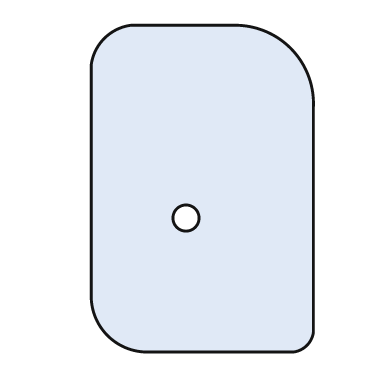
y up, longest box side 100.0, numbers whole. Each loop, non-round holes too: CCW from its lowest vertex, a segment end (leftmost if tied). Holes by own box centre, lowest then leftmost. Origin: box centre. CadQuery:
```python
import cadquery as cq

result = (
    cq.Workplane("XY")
    .moveTo(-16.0, -50.0)
    .lineTo(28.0, -50.0)
    .threePointArc((32.0, -48.0), (34.0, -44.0))
    .lineTo(34.0, 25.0)
    .threePointArc((27.0, 43.0), (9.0, 50.0))
    .lineTo(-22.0, 50.0)
    .threePointArc((-30.0, 46.0), (-34.0, 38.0))
    .lineTo(-34.0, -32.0)
    .threePointArc((-29.0, -45.0), (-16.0, -50.0))
    .close()
    .moveTo(-5.0, -9.0)
    .circle(4.0)
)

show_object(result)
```